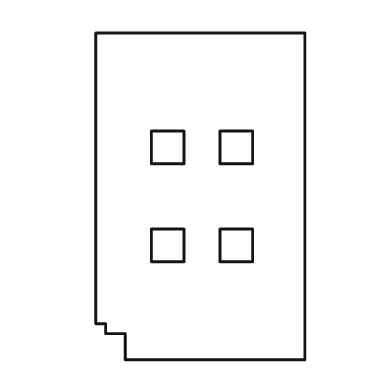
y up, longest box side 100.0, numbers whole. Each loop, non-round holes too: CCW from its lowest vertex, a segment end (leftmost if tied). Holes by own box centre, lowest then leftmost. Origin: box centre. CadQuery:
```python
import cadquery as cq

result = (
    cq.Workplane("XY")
    .moveTo(-23.0, -50.0)
    .lineTo(32.0, -50.0)
    .lineTo(32.0, 50.0)
    .lineTo(-32.0, 50.0)
    .lineTo(-32.0, -39.0)
    .lineTo(-29.0, -39.0)
    .lineTo(-29.0, -42.0)
    .lineTo(-23.0, -42.0)
    .close()
    .moveTo(-15.0, -20.0)
    .lineTo(-5.0, -20.0)
    .lineTo(-5.0, -10.0)
    .lineTo(-15.0, -10.0)
    .close()
    .moveTo(6.0, -20.0)
    .lineTo(16.0, -20.0)
    .lineTo(16.0, -10.0)
    .lineTo(6.0, -10.0)
    .close()
    .moveTo(-15.0, 10.0)
    .lineTo(-5.0, 10.0)
    .lineTo(-5.0, 20.0)
    .lineTo(-15.0, 20.0)
    .close()
    .moveTo(6.0, 10.0)
    .lineTo(16.0, 10.0)
    .lineTo(16.0, 20.0)
    .lineTo(6.0, 20.0)
    .close()
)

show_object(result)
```